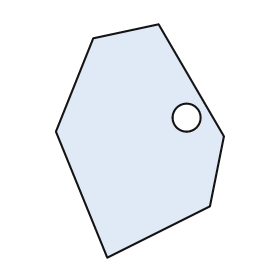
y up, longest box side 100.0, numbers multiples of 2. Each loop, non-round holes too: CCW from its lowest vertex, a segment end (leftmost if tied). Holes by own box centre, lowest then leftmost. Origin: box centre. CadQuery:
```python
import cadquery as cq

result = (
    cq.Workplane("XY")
    .moveTo(-14.0, -50.0)
    .lineTo(30.0, -28.0)
    .lineTo(36.0, 2.0)
    .lineTo(8.0, 50.0)
    .lineTo(-20.0, 44.0)
    .lineTo(-36.0, 4.0)
    .close()
    .moveTo(20.0, 10.0)
    .circle(6.0)
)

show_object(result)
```